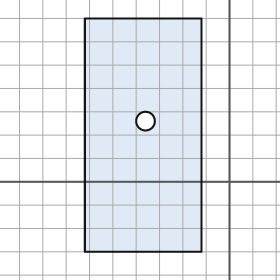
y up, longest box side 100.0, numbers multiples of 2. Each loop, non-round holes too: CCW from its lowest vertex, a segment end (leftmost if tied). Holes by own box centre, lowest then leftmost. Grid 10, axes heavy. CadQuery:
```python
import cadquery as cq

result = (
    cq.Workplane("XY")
    .moveTo(-62.0, -30.0)
    .lineTo(-12.0, -30.0)
    .lineTo(-12.0, 70.0)
    .lineTo(-62.0, 70.0)
    .close()
    .moveTo(-36.0, 26.0)
    .circle(4.0)
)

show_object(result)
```